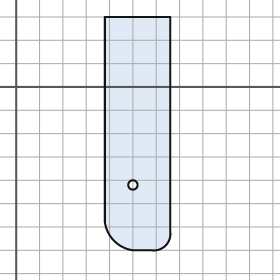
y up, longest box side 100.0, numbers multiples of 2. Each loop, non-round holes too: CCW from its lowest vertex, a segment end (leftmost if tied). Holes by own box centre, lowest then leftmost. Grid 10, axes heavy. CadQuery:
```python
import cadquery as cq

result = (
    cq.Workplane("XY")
    .moveTo(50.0, -70.0)
    .lineTo(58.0, -70.0)
    .threePointArc((64.0, -68.0), (66.0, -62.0))
    .lineTo(66.0, 30.0)
    .lineTo(38.0, 30.0)
    .lineTo(38.0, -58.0)
    .threePointArc((42.0, -66.0), (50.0, -70.0))
    .close()
    .moveTo(50.0, -42.0)
    .circle(2.0)
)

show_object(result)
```